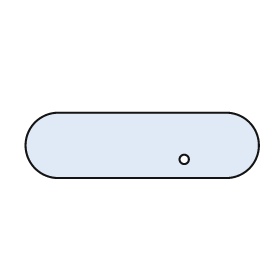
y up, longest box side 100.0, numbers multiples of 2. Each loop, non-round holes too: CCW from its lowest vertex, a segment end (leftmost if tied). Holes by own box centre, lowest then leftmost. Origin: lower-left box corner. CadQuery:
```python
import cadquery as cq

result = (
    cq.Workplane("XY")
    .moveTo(14.0, 0.0)
    .lineTo(86.0, 0.0)
    .threePointArc((100.0, 14.0), (86.0, 28.0))
    .lineTo(14.0, 28.0)
    .threePointArc((0.0, 14.0), (14.0, 0.0))
    .close()
    .moveTo(68.0, 8.0)
    .circle(2.0)
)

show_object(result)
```